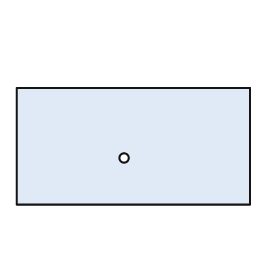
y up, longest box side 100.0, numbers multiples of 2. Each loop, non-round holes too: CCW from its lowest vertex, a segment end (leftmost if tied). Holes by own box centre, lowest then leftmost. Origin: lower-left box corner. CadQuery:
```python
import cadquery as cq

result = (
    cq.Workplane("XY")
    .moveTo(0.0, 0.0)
    .lineTo(100.0, 0.0)
    .lineTo(100.0, 50.0)
    .lineTo(0.0, 50.0)
    .close()
    .moveTo(46.0, 20.0)
    .circle(2.0)
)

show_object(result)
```